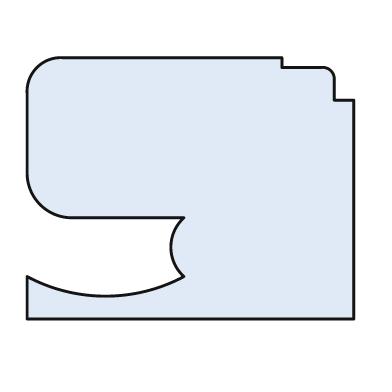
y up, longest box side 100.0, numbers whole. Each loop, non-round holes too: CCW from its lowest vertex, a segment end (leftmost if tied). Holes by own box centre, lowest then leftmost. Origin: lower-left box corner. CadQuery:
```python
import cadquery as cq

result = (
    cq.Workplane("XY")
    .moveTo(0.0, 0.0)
    .lineTo(100.0, 0.0)
    .lineTo(100.0, 67.0)
    .lineTo(94.0, 67.0)
    .lineTo(94.0, 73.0)
    .threePointArc((93.0, 76.0), (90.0, 77.0))
    .lineTo(78.0, 77.0)
    .lineTo(78.0, 80.0)
    .lineTo(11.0, 80.0)
    .threePointArc((3.0, 77.0), (0.0, 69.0))
    .lineTo(0.0, 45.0)
    .threePointArc((4.0, 35.0), (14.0, 31.0))
    .lineTo(48.0, 31.0)
    .threePointArc((44.0, 22.0), (48.0, 13.0))
    .threePointArc((24.0, 7.0), (0.0, 13.0))
    .close()
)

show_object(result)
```